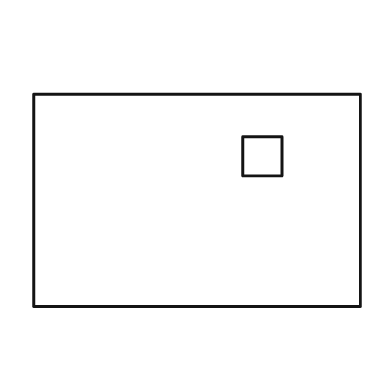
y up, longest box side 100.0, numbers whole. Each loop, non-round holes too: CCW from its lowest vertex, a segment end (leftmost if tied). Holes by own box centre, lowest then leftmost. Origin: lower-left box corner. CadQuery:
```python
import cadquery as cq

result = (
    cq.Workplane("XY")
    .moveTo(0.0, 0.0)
    .lineTo(100.0, 0.0)
    .lineTo(100.0, 65.0)
    .lineTo(0.0, 65.0)
    .close()
    .moveTo(64.0, 40.0)
    .lineTo(76.0, 40.0)
    .lineTo(76.0, 52.0)
    .lineTo(64.0, 52.0)
    .close()
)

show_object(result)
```